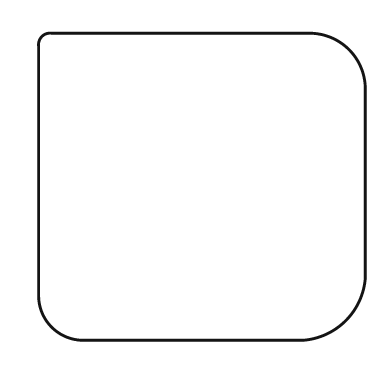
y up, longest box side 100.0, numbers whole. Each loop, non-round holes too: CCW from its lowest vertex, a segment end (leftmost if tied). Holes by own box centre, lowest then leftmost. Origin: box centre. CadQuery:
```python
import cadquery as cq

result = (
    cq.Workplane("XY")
    .moveTo(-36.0, -47.0)
    .lineTo(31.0, -47.0)
    .threePointArc((44.0, -41.0), (50.0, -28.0))
    .lineTo(50.0, 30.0)
    .threePointArc((45.0, 42.0), (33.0, 47.0))
    .lineTo(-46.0, 47.0)
    .threePointArc((-49.0, 46.0), (-50.0, 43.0))
    .lineTo(-50.0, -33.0)
    .threePointArc((-46.0, -43.0), (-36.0, -47.0))
    .close()
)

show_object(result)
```